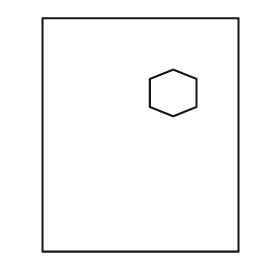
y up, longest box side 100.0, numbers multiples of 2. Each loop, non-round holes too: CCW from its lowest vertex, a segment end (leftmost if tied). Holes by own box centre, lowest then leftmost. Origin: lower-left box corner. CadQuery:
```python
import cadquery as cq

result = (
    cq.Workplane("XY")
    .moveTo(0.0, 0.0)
    .lineTo(84.0, 0.0)
    .lineTo(84.0, 100.0)
    .lineTo(0.0, 100.0)
    .close()
    .moveTo(56.0, 58.0)
    .lineTo(66.0, 62.0)
    .lineTo(66.0, 74.0)
    .lineTo(56.0, 78.0)
    .lineTo(46.0, 74.0)
    .lineTo(46.0, 62.0)
    .close()
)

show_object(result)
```